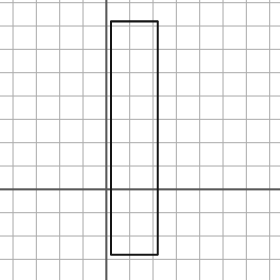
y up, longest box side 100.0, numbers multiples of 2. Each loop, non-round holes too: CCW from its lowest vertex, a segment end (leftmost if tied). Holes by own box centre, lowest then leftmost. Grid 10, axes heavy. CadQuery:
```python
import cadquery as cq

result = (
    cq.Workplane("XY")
    .moveTo(2.0, -28.0)
    .lineTo(22.0, -28.0)
    .lineTo(22.0, 72.0)
    .lineTo(2.0, 72.0)
    .close()
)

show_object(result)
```